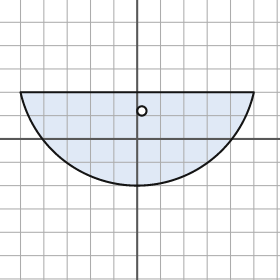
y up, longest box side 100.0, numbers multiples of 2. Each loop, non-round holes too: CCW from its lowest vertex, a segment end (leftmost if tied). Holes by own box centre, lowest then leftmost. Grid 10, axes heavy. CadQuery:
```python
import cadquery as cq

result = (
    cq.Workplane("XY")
    .moveTo(-50.0, 20.0)
    .threePointArc((0.0, -20.0), (50.0, 20.0))
    .close()
    .moveTo(2.0, 12.0)
    .circle(2.0)
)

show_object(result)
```